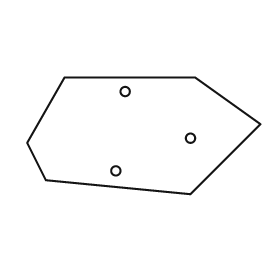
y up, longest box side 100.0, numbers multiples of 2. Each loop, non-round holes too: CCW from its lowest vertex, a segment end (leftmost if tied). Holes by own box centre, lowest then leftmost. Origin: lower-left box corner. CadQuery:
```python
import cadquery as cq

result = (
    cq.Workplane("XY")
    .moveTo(70.0, 0.0)
    .lineTo(100.0, 30.0)
    .lineTo(72.0, 50.0)
    .lineTo(16.0, 50.0)
    .lineTo(0.0, 22.0)
    .lineTo(8.0, 6.0)
    .close()
    .moveTo(38.0, 10.0)
    .circle(2.0)
    .moveTo(70.0, 24.0)
    .circle(2.0)
    .moveTo(42.0, 44.0)
    .circle(2.0)
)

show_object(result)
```